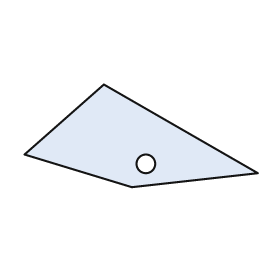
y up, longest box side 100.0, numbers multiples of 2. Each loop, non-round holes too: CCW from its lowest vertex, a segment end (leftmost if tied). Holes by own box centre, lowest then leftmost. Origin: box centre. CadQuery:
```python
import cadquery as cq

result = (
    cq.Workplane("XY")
    .moveTo(-4.0, -22.0)
    .lineTo(50.0, -16.0)
    .lineTo(-16.0, 22.0)
    .lineTo(-50.0, -8.0)
    .close()
    .moveTo(2.0, -12.0)
    .circle(4.0)
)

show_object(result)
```